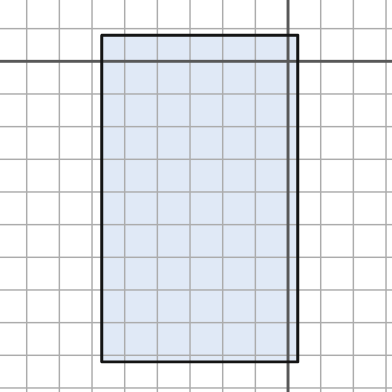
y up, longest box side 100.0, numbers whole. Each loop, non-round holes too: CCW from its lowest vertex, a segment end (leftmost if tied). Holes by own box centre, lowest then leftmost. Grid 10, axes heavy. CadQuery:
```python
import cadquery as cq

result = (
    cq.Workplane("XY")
    .moveTo(-57.0, -92.0)
    .lineTo(3.0, -92.0)
    .lineTo(3.0, 8.0)
    .lineTo(-57.0, 8.0)
    .close()
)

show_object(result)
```